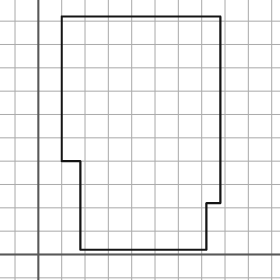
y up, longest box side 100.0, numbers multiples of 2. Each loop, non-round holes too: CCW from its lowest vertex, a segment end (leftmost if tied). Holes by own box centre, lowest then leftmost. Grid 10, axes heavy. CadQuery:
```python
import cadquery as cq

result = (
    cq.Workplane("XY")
    .moveTo(18.0, 2.0)
    .lineTo(72.0, 2.0)
    .lineTo(72.0, 22.0)
    .lineTo(78.0, 22.0)
    .lineTo(78.0, 102.0)
    .lineTo(10.0, 102.0)
    .lineTo(10.0, 40.0)
    .lineTo(18.0, 40.0)
    .close()
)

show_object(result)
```